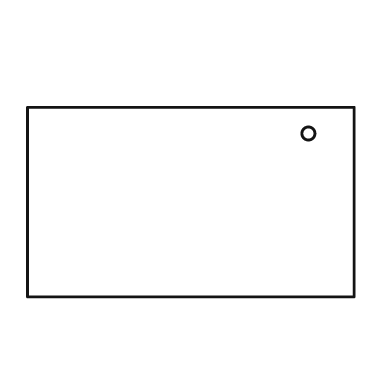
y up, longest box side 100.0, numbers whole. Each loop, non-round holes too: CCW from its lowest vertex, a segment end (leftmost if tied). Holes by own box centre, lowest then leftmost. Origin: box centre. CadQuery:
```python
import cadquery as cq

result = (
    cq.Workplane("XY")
    .moveTo(-50.0, -29.0)
    .lineTo(50.0, -29.0)
    .lineTo(50.0, 29.0)
    .lineTo(-50.0, 29.0)
    .close()
    .moveTo(36.0, 21.0)
    .circle(2.0)
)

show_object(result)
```